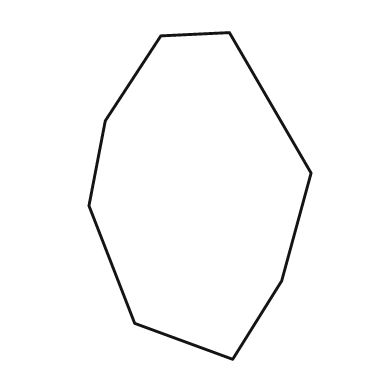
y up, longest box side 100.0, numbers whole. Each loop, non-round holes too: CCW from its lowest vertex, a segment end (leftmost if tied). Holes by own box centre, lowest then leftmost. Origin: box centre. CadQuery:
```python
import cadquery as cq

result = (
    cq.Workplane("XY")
    .moveTo(10.0, -50.0)
    .lineTo(25.0, -26.0)
    .lineTo(34.0, 7.0)
    .lineTo(9.0, 50.0)
    .lineTo(-12.0, 49.0)
    .lineTo(-29.0, 23.0)
    .lineTo(-34.0, -3.0)
    .lineTo(-20.0, -39.0)
    .close()
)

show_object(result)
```